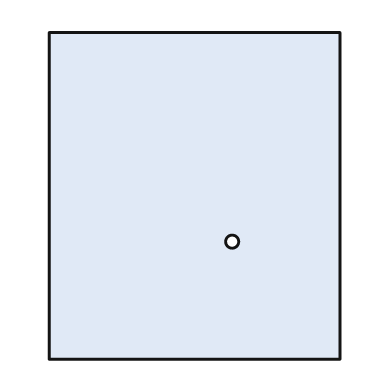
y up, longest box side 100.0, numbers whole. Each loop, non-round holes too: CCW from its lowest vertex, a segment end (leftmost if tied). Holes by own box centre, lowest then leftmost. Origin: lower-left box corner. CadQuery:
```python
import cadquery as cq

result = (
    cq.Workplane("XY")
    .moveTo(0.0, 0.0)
    .lineTo(89.0, 0.0)
    .lineTo(89.0, 100.0)
    .lineTo(0.0, 100.0)
    .close()
    .moveTo(56.0, 36.0)
    .circle(2.0)
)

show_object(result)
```